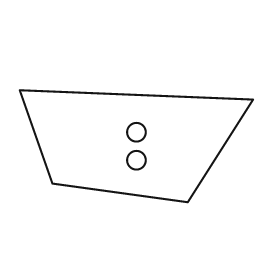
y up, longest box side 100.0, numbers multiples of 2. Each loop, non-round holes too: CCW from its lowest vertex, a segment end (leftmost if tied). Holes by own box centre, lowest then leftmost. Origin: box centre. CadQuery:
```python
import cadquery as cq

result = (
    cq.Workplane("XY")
    .moveTo(22.0, -24.0)
    .lineTo(50.0, 20.0)
    .lineTo(-50.0, 24.0)
    .lineTo(-36.0, -16.0)
    .close()
    .moveTo(0.0, -6.0)
    .circle(4.0)
    .moveTo(0.0, 6.0)
    .circle(4.0)
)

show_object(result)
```